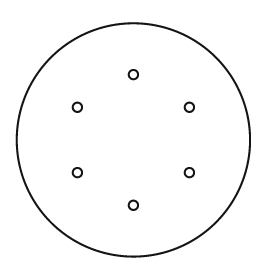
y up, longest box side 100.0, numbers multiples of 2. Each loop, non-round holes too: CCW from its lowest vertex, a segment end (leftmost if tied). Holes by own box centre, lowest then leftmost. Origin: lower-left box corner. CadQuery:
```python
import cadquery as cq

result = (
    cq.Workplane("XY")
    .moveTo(50.0, 50.0)
    .circle(50.0)
    .moveTo(50.0, 22.0)
    .circle(2.0)
    .moveTo(26.0, 36.0)
    .circle(2.0)
    .moveTo(74.0, 36.0)
    .circle(2.0)
    .moveTo(26.0, 64.0)
    .circle(2.0)
    .moveTo(74.0, 64.0)
    .circle(2.0)
    .moveTo(50.0, 78.0)
    .circle(2.0)
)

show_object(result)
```